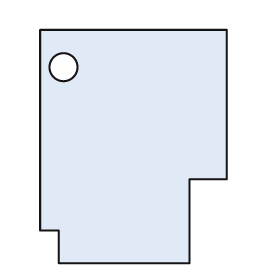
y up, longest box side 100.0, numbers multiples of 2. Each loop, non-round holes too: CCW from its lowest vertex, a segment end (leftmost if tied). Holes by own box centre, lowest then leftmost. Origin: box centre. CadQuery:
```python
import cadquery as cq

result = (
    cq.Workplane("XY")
    .moveTo(-32.0, -50.0)
    .lineTo(24.0, -50.0)
    .lineTo(24.0, -14.0)
    .lineTo(40.0, -14.0)
    .lineTo(40.0, 50.0)
    .lineTo(-40.0, 50.0)
    .lineTo(-40.0, -36.0)
    .lineTo(-32.0, -36.0)
    .close()
    .moveTo(-30.0, 34.0)
    .circle(6.0)
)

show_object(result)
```